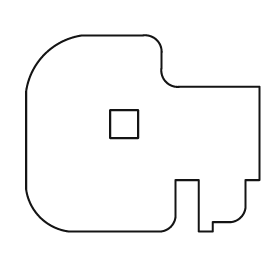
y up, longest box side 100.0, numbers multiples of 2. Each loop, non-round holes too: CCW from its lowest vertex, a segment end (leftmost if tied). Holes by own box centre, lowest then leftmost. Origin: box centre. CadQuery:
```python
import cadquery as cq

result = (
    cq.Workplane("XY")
    .moveTo(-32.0, -42.0)
    .lineTo(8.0, -42.0)
    .threePointArc((12.0, -40.0), (14.0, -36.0))
    .lineTo(14.0, -20.0)
    .lineTo(24.0, -20.0)
    .lineTo(24.0, -42.0)
    .lineTo(30.0, -42.0)
    .lineTo(30.0, -38.0)
    .lineTo(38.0, -38.0)
    .threePointArc((42.0, -36.0), (44.0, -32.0))
    .lineTo(44.0, -20.0)
    .lineTo(50.0, -20.0)
    .lineTo(50.0, 20.0)
    .lineTo(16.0, 20.0)
    .threePointArc((10.0, 22.0), (8.0, 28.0))
    .lineTo(8.0, 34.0)
    .threePointArc((6.0, 40.0), (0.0, 42.0))
    .lineTo(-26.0, 42.0)
    .threePointArc((-42.0, 34.0), (-50.0, 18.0))
    .lineTo(-50.0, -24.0)
    .threePointArc((-44.0, -36.0), (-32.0, -42.0))
    .close()
    .moveTo(-14.0, -2.0)
    .lineTo(-2.0, -2.0)
    .lineTo(-2.0, 10.0)
    .lineTo(-14.0, 10.0)
    .close()
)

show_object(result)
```